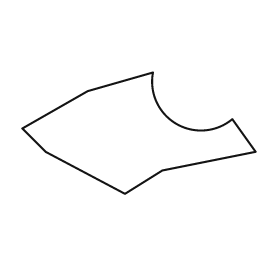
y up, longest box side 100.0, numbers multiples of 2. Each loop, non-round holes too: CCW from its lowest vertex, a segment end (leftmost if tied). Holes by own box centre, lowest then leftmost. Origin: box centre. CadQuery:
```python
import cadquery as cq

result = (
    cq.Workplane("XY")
    .moveTo(-6.0, -26.0)
    .lineTo(10.0, -16.0)
    .lineTo(50.0, -8.0)
    .lineTo(40.0, 6.0)
    .threePointArc((16.0, 4.0), (6.0, 26.0))
    .lineTo(-22.0, 18.0)
    .lineTo(-50.0, 2.0)
    .lineTo(-40.0, -8.0)
    .close()
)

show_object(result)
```